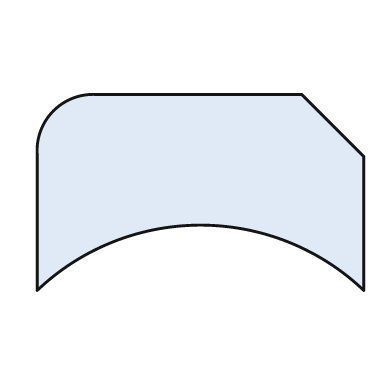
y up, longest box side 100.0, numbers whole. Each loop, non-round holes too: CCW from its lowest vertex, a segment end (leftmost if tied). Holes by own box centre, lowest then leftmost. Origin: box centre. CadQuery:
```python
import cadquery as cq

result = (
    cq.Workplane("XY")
    .moveTo(-50.0, -30.0)
    .threePointArc((0.0, -10.0), (50.0, -30.0))
    .lineTo(50.0, 11.0)
    .lineTo(31.0, 30.0)
    .lineTo(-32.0, 30.0)
    .threePointArc((-45.0, 25.0), (-50.0, 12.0))
    .close()
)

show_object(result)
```